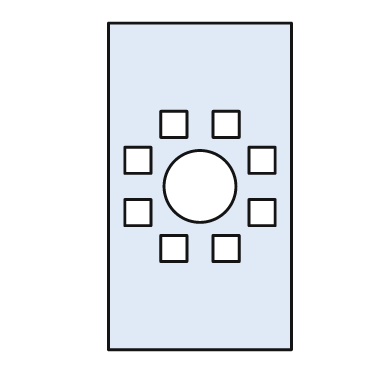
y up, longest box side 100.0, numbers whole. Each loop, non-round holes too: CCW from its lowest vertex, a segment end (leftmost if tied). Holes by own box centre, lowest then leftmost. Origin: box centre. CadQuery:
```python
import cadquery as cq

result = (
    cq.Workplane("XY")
    .moveTo(-28.0, -50.0)
    .lineTo(28.0, -50.0)
    .lineTo(28.0, 50.0)
    .lineTo(-28.0, 50.0)
    .close()
    .moveTo(-12.0, -23.0)
    .lineTo(-4.0, -23.0)
    .lineTo(-4.0, -15.0)
    .lineTo(-12.0, -15.0)
    .close()
    .moveTo(4.0, -23.0)
    .lineTo(12.0, -23.0)
    .lineTo(12.0, -15.0)
    .lineTo(4.0, -15.0)
    .close()
    .moveTo(-23.0, -12.0)
    .lineTo(-15.0, -12.0)
    .lineTo(-15.0, -4.0)
    .lineTo(-23.0, -4.0)
    .close()
    .moveTo(15.0, -12.0)
    .lineTo(23.0, -12.0)
    .lineTo(23.0, -4.0)
    .lineTo(15.0, -4.0)
    .close()
    .moveTo(0.0, 0.0)
    .circle(11.0)
    .moveTo(-23.0, 4.0)
    .lineTo(-15.0, 4.0)
    .lineTo(-15.0, 12.0)
    .lineTo(-23.0, 12.0)
    .close()
    .moveTo(15.0, 4.0)
    .lineTo(23.0, 4.0)
    .lineTo(23.0, 12.0)
    .lineTo(15.0, 12.0)
    .close()
    .moveTo(-12.0, 15.0)
    .lineTo(-4.0, 15.0)
    .lineTo(-4.0, 23.0)
    .lineTo(-12.0, 23.0)
    .close()
    .moveTo(4.0, 15.0)
    .lineTo(12.0, 15.0)
    .lineTo(12.0, 23.0)
    .lineTo(4.0, 23.0)
    .close()
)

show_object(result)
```